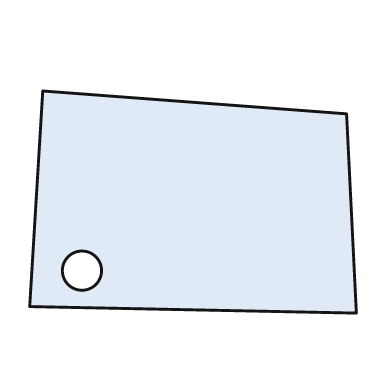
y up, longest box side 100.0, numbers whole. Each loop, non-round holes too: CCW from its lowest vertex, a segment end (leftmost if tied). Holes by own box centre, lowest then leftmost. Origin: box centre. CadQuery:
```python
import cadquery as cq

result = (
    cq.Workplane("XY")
    .moveTo(50.0, -34.0)
    .lineTo(47.0, 27.0)
    .lineTo(-46.0, 34.0)
    .lineTo(-50.0, -32.0)
    .close()
    .moveTo(-34.0, -21.0)
    .circle(6.0)
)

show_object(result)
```